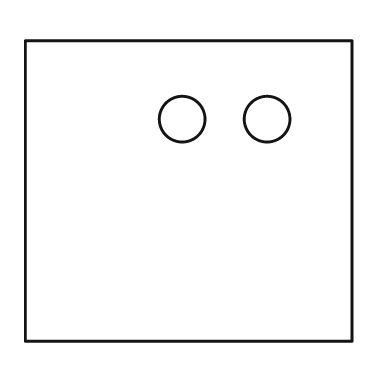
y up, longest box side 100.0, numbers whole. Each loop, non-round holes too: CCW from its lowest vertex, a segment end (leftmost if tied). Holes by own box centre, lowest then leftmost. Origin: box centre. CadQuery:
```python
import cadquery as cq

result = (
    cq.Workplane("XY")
    .moveTo(-50.0, -46.0)
    .lineTo(50.0, -46.0)
    .lineTo(50.0, 46.0)
    .lineTo(-50.0, 46.0)
    .close()
    .moveTo(-2.0, 22.0)
    .circle(7.0)
    .moveTo(24.0, 22.0)
    .circle(7.0)
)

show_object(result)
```